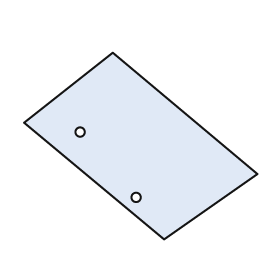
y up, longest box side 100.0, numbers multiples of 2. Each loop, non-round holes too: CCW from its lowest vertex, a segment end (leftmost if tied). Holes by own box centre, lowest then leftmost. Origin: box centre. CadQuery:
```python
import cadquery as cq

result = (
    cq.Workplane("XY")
    .moveTo(10.0, -40.0)
    .lineTo(50.0, -12.0)
    .lineTo(-12.0, 40.0)
    .lineTo(-50.0, 10.0)
    .close()
    .moveTo(-2.0, -22.0)
    .circle(2.0)
    .moveTo(-26.0, 6.0)
    .circle(2.0)
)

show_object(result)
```